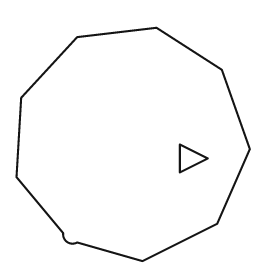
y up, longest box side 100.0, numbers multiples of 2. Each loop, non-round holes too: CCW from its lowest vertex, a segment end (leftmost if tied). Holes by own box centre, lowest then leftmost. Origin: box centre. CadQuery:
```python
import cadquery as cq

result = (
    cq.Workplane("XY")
    .moveTo(4.0, -50.0)
    .lineTo(36.0, -34.0)
    .lineTo(50.0, -2.0)
    .lineTo(38.0, 32.0)
    .lineTo(10.0, 50.0)
    .lineTo(-24.0, 46.0)
    .lineTo(-48.0, 20.0)
    .lineTo(-50.0, -14.0)
    .lineTo(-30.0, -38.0)
    .threePointArc((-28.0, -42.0), (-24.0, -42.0))
    .close()
    .moveTo(20.0, -12.0)
    .lineTo(32.0, -6.0)
    .lineTo(20.0, 0.0)
    .close()
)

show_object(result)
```